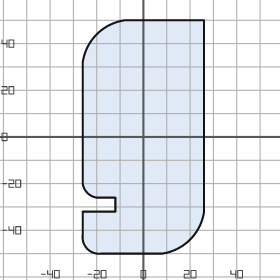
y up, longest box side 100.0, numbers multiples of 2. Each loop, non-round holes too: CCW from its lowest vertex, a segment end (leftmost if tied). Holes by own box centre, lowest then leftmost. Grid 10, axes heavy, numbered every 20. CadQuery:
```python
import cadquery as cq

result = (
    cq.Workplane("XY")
    .moveTo(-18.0, -50.0)
    .lineTo(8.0, -50.0)
    .threePointArc((20.0, -44.0), (26.0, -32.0))
    .lineTo(26.0, 50.0)
    .lineTo(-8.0, 50.0)
    .threePointArc((-20.0, 44.0), (-26.0, 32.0))
    .lineTo(-26.0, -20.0)
    .threePointArc((-24.0, -24.0), (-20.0, -26.0))
    .lineTo(-12.0, -26.0)
    .lineTo(-12.0, -32.0)
    .lineTo(-26.0, -32.0)
    .lineTo(-26.0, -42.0)
    .threePointArc((-24.0, -48.0), (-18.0, -50.0))
    .close()
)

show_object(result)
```